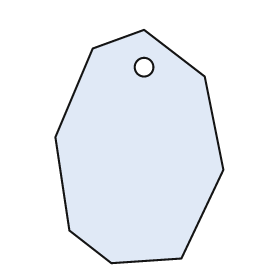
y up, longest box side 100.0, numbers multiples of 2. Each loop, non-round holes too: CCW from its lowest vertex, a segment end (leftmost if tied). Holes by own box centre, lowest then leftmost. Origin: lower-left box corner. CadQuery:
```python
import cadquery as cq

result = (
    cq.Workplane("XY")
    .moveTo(24.0, 0.0)
    .lineTo(54.0, 2.0)
    .lineTo(72.0, 40.0)
    .lineTo(64.0, 80.0)
    .lineTo(38.0, 100.0)
    .lineTo(16.0, 92.0)
    .lineTo(0.0, 54.0)
    .lineTo(6.0, 14.0)
    .close()
    .moveTo(38.0, 84.0)
    .circle(4.0)
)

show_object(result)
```